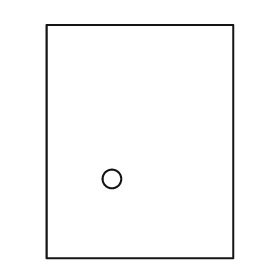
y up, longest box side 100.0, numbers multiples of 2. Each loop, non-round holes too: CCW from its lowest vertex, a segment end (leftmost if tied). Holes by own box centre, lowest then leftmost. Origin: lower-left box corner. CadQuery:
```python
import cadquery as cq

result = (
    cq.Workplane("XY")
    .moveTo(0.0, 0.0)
    .lineTo(80.0, 0.0)
    .lineTo(80.0, 100.0)
    .lineTo(0.0, 100.0)
    .close()
    .moveTo(28.0, 34.0)
    .circle(4.0)
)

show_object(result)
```